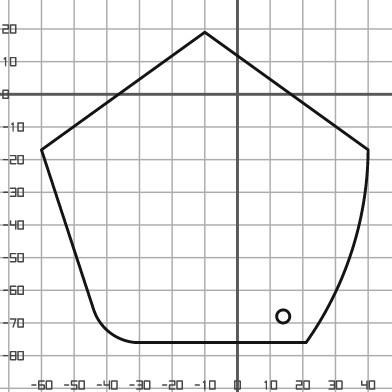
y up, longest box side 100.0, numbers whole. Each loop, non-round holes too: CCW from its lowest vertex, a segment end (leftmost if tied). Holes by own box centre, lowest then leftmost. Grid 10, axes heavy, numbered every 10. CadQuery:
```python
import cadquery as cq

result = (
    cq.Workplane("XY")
    .moveTo(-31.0, -76.0)
    .lineTo(21.0, -76.0)
    .threePointArc((35.0, -48.0), (40.0, -17.0))
    .lineTo(-10.0, 19.0)
    .lineTo(-60.0, -17.0)
    .lineTo(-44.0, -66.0)
    .threePointArc((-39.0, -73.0), (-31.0, -76.0))
    .close()
    .moveTo(14.0, -68.0)
    .circle(2.0)
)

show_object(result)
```